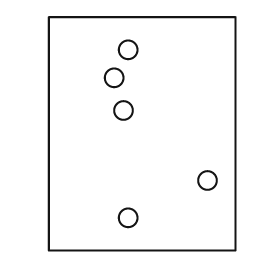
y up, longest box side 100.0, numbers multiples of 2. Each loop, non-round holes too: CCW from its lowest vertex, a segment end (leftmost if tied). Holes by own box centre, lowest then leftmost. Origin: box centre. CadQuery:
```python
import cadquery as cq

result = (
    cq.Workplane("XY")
    .moveTo(-40.0, -50.0)
    .lineTo(40.0, -50.0)
    .lineTo(40.0, 50.0)
    .lineTo(-40.0, 50.0)
    .close()
    .moveTo(-6.0, -36.0)
    .circle(4.0)
    .moveTo(28.0, -20.0)
    .circle(4.0)
    .moveTo(-8.0, 10.0)
    .circle(4.0)
    .moveTo(-12.0, 24.0)
    .circle(4.0)
    .moveTo(-6.0, 36.0)
    .circle(4.0)
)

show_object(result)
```